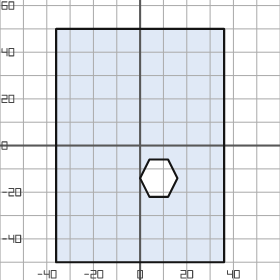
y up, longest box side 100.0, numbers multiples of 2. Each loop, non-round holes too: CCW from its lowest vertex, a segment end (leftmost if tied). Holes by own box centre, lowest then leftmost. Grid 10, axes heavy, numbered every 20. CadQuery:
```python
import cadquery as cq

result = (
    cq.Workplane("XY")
    .moveTo(-36.0, -50.0)
    .lineTo(36.0, -50.0)
    .lineTo(36.0, 50.0)
    .lineTo(-36.0, 50.0)
    .close()
    .moveTo(4.0, -22.0)
    .lineTo(12.0, -22.0)
    .lineTo(16.0, -14.0)
    .lineTo(12.0, -6.0)
    .lineTo(4.0, -6.0)
    .lineTo(0.0, -14.0)
    .close()
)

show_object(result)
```